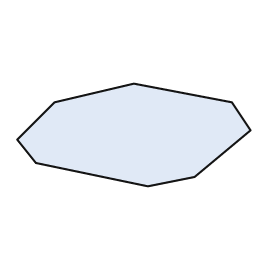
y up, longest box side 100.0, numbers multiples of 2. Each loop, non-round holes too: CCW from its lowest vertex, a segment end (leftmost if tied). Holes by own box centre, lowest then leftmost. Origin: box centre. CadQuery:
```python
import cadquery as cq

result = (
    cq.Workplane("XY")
    .moveTo(6.0, -22.0)
    .lineTo(26.0, -18.0)
    .lineTo(50.0, 2.0)
    .lineTo(42.0, 14.0)
    .lineTo(0.0, 22.0)
    .lineTo(-34.0, 14.0)
    .lineTo(-50.0, -2.0)
    .lineTo(-42.0, -12.0)
    .close()
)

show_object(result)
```